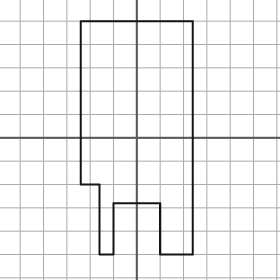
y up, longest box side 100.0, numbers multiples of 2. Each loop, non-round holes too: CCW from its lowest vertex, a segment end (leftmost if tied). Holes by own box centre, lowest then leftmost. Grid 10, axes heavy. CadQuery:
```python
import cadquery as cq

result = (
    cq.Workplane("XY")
    .moveTo(-16.0, -50.0)
    .lineTo(-10.0, -50.0)
    .lineTo(-10.0, -28.0)
    .lineTo(10.0, -28.0)
    .lineTo(10.0, -50.0)
    .lineTo(24.0, -50.0)
    .lineTo(24.0, 50.0)
    .lineTo(-24.0, 50.0)
    .lineTo(-24.0, -20.0)
    .lineTo(-16.0, -20.0)
    .close()
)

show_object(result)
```